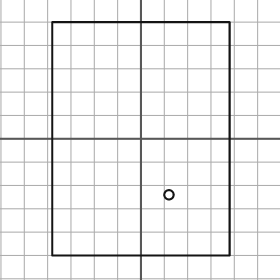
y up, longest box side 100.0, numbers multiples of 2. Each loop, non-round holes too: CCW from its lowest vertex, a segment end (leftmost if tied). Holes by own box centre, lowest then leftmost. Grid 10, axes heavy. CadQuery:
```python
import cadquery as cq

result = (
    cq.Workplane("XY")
    .moveTo(-38.0, -50.0)
    .lineTo(38.0, -50.0)
    .lineTo(38.0, 50.0)
    .lineTo(-38.0, 50.0)
    .close()
    .moveTo(12.0, -24.0)
    .circle(2.0)
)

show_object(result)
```